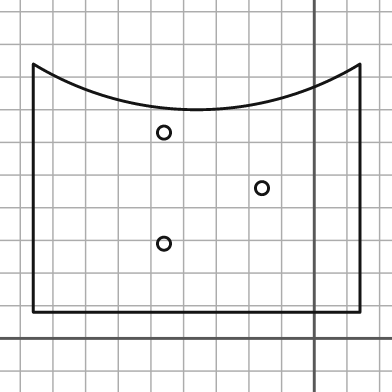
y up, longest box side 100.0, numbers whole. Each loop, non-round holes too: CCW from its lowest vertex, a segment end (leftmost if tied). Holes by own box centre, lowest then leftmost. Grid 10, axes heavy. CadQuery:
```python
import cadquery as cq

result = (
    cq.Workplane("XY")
    .moveTo(-86.0, 8.0)
    .lineTo(14.0, 8.0)
    .lineTo(14.0, 84.0)
    .threePointArc((-36.0, 70.0), (-86.0, 84.0))
    .close()
    .moveTo(-46.0, 29.0)
    .circle(2.0)
    .moveTo(-16.0, 46.0)
    .circle(2.0)
    .moveTo(-46.0, 63.0)
    .circle(2.0)
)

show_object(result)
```